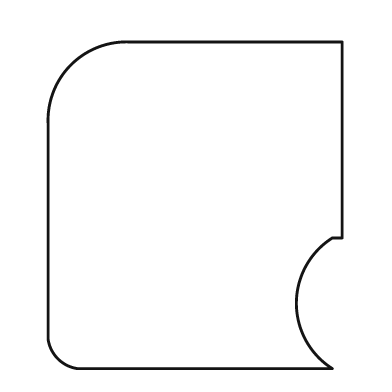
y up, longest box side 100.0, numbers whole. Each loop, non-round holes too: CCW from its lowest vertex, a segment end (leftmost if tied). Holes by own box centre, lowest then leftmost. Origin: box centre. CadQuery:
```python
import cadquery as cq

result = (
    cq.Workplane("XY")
    .moveTo(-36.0, -50.0)
    .lineTo(42.0, -50.0)
    .threePointArc((31.0, -30.0), (42.0, -10.0))
    .lineTo(45.0, -10.0)
    .lineTo(45.0, 50.0)
    .lineTo(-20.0, 50.0)
    .threePointArc((-38.0, 43.0), (-45.0, 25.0))
    .lineTo(-45.0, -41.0)
    .threePointArc((-42.0, -47.0), (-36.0, -50.0))
    .close()
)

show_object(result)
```